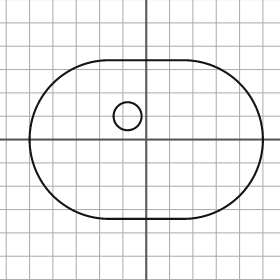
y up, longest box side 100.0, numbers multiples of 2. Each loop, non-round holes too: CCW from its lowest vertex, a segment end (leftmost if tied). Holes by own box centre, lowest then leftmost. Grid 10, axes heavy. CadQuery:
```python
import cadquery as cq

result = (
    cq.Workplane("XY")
    .moveTo(-16.0, -34.0)
    .lineTo(16.0, -34.0)
    .threePointArc((50.0, 0.0), (16.0, 34.0))
    .lineTo(-16.0, 34.0)
    .threePointArc((-50.0, 0.0), (-16.0, -34.0))
    .close()
    .moveTo(-8.0, 10.0)
    .circle(6.0)
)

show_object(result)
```